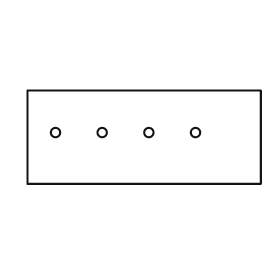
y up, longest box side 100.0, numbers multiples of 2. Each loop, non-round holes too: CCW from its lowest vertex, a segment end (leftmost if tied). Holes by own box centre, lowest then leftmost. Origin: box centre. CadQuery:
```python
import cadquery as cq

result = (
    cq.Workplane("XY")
    .moveTo(-50.0, -20.0)
    .lineTo(50.0, -20.0)
    .lineTo(50.0, 20.0)
    .lineTo(-50.0, 20.0)
    .close()
    .moveTo(-38.0, 2.0)
    .circle(2.0)
    .moveTo(-18.0, 2.0)
    .circle(2.0)
    .moveTo(2.0, 2.0)
    .circle(2.0)
    .moveTo(22.0, 2.0)
    .circle(2.0)
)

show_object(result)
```